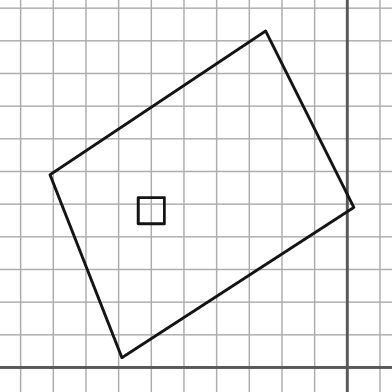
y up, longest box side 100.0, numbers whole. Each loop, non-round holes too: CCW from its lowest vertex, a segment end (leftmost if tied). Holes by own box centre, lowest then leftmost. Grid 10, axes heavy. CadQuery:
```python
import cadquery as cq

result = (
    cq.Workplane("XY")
    .moveTo(-69.0, 3.0)
    .lineTo(2.0, 49.0)
    .lineTo(-25.0, 103.0)
    .lineTo(-91.0, 59.0)
    .close()
    .moveTo(-64.0, 44.0)
    .lineTo(-56.0, 44.0)
    .lineTo(-56.0, 52.0)
    .lineTo(-64.0, 52.0)
    .close()
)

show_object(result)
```